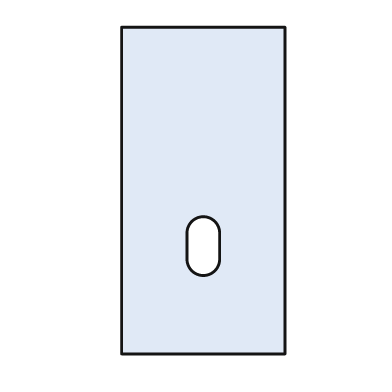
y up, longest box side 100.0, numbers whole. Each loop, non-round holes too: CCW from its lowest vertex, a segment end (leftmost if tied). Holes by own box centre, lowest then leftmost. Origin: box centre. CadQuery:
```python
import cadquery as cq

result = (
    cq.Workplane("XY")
    .moveTo(-25.0, -50.0)
    .lineTo(25.0, -50.0)
    .lineTo(25.0, 50.0)
    .lineTo(-25.0, 50.0)
    .close()
    .moveTo(-5.0, -21.0)
    .threePointArc((0.0, -26.0), (5.0, -21.0))
    .lineTo(5.0, -13.0)
    .threePointArc((0.0, -8.0), (-5.0, -13.0))
    .close()
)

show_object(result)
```